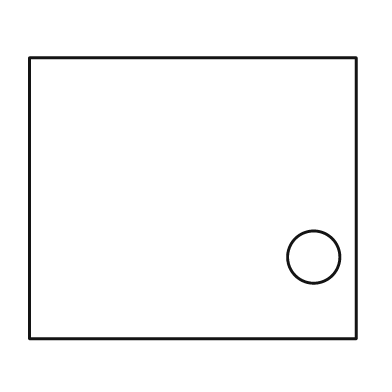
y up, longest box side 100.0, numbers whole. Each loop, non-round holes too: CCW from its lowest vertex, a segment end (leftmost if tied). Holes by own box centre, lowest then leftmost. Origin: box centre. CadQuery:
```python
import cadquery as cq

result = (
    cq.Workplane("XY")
    .moveTo(-50.0, -43.0)
    .lineTo(50.0, -43.0)
    .lineTo(50.0, 43.0)
    .lineTo(-50.0, 43.0)
    .close()
    .moveTo(37.0, -18.0)
    .circle(8.0)
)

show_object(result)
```